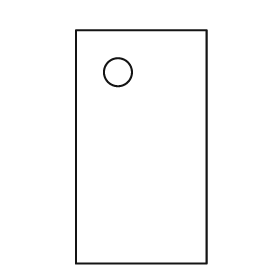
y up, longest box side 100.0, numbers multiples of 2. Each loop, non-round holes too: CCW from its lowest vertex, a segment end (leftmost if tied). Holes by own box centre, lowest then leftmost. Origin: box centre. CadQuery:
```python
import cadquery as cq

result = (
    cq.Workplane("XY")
    .moveTo(-28.0, -50.0)
    .lineTo(28.0, -50.0)
    .lineTo(28.0, 50.0)
    .lineTo(-28.0, 50.0)
    .close()
    .moveTo(-10.0, 32.0)
    .circle(6.0)
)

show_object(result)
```